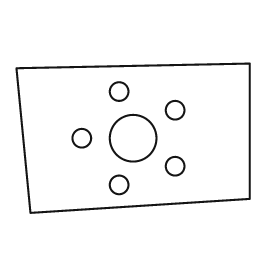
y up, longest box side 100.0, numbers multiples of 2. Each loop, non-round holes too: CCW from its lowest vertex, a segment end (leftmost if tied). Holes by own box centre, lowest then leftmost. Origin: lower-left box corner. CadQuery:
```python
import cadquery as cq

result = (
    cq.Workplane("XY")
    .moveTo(6.0, 0.0)
    .lineTo(100.0, 6.0)
    .lineTo(100.0, 64.0)
    .lineTo(0.0, 62.0)
    .close()
    .moveTo(44.0, 12.0)
    .circle(4.0)
    .moveTo(68.0, 20.0)
    .circle(4.0)
    .moveTo(28.0, 32.0)
    .circle(4.0)
    .moveTo(50.0, 32.0)
    .circle(10.0)
    .moveTo(68.0, 44.0)
    .circle(4.0)
    .moveTo(44.0, 52.0)
    .circle(4.0)
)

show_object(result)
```